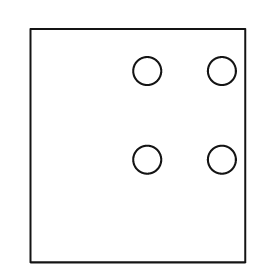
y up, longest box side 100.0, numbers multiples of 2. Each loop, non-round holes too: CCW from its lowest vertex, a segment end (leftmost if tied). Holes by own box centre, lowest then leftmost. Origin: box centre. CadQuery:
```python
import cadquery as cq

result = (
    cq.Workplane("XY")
    .moveTo(-46.0, -50.0)
    .lineTo(46.0, -50.0)
    .lineTo(46.0, 50.0)
    .lineTo(-46.0, 50.0)
    .close()
    .moveTo(4.0, -6.0)
    .circle(6.0)
    .moveTo(36.0, -6.0)
    .circle(6.0)
    .moveTo(4.0, 32.0)
    .circle(6.0)
    .moveTo(36.0, 32.0)
    .circle(6.0)
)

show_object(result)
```